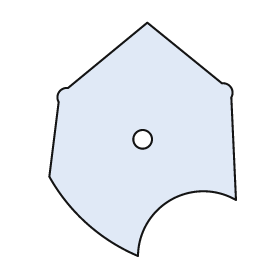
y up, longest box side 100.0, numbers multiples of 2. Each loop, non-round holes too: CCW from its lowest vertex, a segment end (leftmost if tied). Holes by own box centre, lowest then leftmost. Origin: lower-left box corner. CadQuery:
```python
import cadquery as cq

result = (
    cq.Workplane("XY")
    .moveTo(38.0, 0.0)
    .threePointArc((52.0, 24.0), (80.0, 24.0))
    .lineTo(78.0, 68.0)
    .threePointArc((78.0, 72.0), (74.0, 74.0))
    .lineTo(42.0, 100.0)
    .lineTo(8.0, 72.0)
    .threePointArc((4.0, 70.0), (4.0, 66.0))
    .lineTo(0.0, 34.0)
    .threePointArc((16.0, 14.0), (38.0, 0.0))
    .close()
    .moveTo(40.0, 50.0)
    .circle(4.0)
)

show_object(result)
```